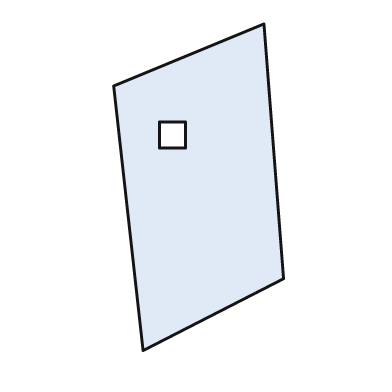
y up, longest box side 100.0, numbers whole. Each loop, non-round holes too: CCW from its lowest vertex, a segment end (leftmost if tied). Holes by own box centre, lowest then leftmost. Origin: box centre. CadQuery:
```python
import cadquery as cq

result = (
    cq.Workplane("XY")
    .moveTo(-17.0, -50.0)
    .lineTo(26.0, -28.0)
    .lineTo(20.0, 50.0)
    .lineTo(-26.0, 31.0)
    .close()
    .moveTo(-12.0, 12.0)
    .lineTo(-4.0, 12.0)
    .lineTo(-4.0, 20.0)
    .lineTo(-12.0, 20.0)
    .close()
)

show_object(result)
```